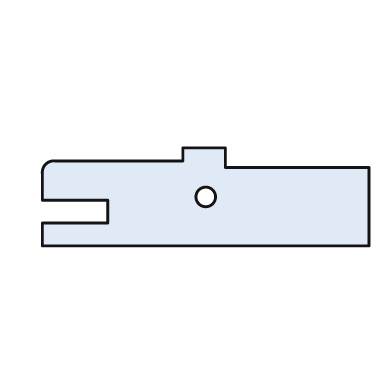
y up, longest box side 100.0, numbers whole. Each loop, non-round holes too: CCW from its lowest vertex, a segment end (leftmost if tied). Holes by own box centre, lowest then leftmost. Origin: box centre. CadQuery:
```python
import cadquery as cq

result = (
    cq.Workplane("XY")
    .moveTo(-50.0, -15.0)
    .lineTo(50.0, -15.0)
    .lineTo(50.0, 9.0)
    .lineTo(6.0, 9.0)
    .lineTo(6.0, 15.0)
    .lineTo(-7.0, 15.0)
    .lineTo(-7.0, 11.0)
    .lineTo(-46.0, 11.0)
    .threePointArc((-49.0, 10.0), (-50.0, 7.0))
    .lineTo(-50.0, -1.0)
    .lineTo(-30.0, -1.0)
    .lineTo(-30.0, -8.0)
    .lineTo(-50.0, -8.0)
    .close()
    .moveTo(0.0, 0.0)
    .circle(3.0)
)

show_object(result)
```